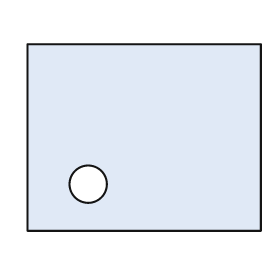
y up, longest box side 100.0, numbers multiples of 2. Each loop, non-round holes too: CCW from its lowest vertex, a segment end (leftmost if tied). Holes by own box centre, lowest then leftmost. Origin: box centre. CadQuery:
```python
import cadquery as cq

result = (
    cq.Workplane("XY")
    .moveTo(-50.0, -40.0)
    .lineTo(50.0, -40.0)
    .lineTo(50.0, 40.0)
    .lineTo(-50.0, 40.0)
    .close()
    .moveTo(-24.0, -20.0)
    .circle(8.0)
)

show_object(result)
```